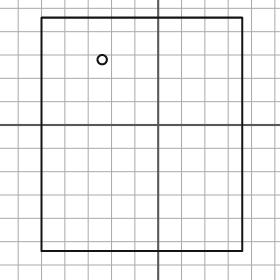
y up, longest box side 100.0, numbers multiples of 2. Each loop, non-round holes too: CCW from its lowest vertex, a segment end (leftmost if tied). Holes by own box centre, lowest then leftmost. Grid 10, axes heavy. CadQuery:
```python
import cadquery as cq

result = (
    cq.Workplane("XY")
    .moveTo(-50.0, -54.0)
    .lineTo(36.0, -54.0)
    .lineTo(36.0, 46.0)
    .lineTo(-50.0, 46.0)
    .close()
    .moveTo(-24.0, 28.0)
    .circle(2.0)
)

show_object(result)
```